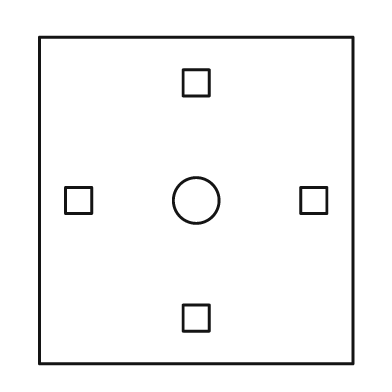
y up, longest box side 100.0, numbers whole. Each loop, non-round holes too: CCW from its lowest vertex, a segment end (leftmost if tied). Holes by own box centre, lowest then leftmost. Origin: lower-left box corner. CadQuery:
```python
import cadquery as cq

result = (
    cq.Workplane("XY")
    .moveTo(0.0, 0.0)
    .lineTo(96.0, 0.0)
    .lineTo(96.0, 100.0)
    .lineTo(0.0, 100.0)
    .close()
    .moveTo(44.0, 10.0)
    .lineTo(52.0, 10.0)
    .lineTo(52.0, 18.0)
    .lineTo(44.0, 18.0)
    .close()
    .moveTo(8.0, 46.0)
    .lineTo(16.0, 46.0)
    .lineTo(16.0, 54.0)
    .lineTo(8.0, 54.0)
    .close()
    .moveTo(48.0, 50.0)
    .circle(7.0)
    .moveTo(80.0, 46.0)
    .lineTo(88.0, 46.0)
    .lineTo(88.0, 54.0)
    .lineTo(80.0, 54.0)
    .close()
    .moveTo(44.0, 82.0)
    .lineTo(52.0, 82.0)
    .lineTo(52.0, 90.0)
    .lineTo(44.0, 90.0)
    .close()
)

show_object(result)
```